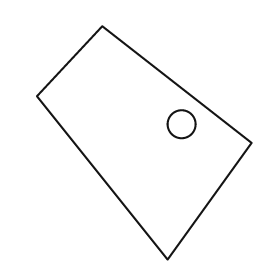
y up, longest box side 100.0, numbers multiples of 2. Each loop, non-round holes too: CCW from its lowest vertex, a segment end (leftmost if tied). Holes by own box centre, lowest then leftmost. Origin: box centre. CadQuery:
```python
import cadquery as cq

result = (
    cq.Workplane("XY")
    .moveTo(10.0, -50.0)
    .lineTo(46.0, 0.0)
    .lineTo(-18.0, 50.0)
    .lineTo(-46.0, 20.0)
    .close()
    .moveTo(16.0, 8.0)
    .circle(6.0)
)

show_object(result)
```